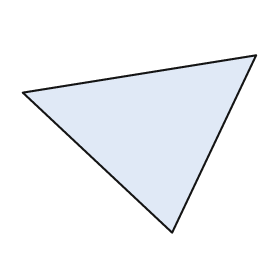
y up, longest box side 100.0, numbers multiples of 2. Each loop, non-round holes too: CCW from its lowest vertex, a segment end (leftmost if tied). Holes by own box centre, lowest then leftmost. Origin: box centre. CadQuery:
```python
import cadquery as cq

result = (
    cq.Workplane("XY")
    .moveTo(14.0, -38.0)
    .lineTo(50.0, 38.0)
    .lineTo(-50.0, 22.0)
    .close()
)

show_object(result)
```